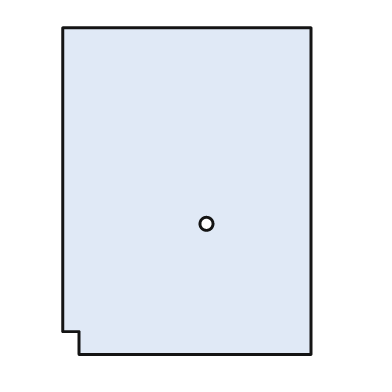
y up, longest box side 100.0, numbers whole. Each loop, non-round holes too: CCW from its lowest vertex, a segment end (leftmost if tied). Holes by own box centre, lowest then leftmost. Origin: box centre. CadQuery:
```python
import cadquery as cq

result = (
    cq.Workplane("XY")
    .moveTo(-33.0, -50.0)
    .lineTo(38.0, -50.0)
    .lineTo(38.0, 50.0)
    .lineTo(-38.0, 50.0)
    .lineTo(-38.0, -43.0)
    .lineTo(-33.0, -43.0)
    .close()
    .moveTo(6.0, -10.0)
    .circle(2.0)
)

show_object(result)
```